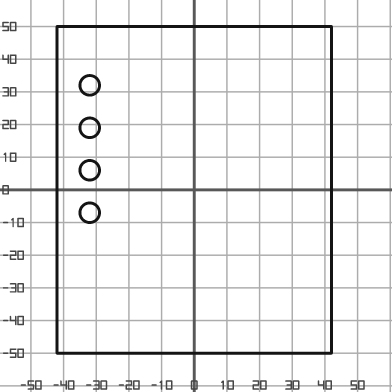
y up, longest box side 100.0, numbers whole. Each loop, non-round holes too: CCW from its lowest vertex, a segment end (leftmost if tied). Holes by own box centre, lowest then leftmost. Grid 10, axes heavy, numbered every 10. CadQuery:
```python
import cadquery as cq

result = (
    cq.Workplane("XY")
    .moveTo(-42.0, -50.0)
    .lineTo(42.0, -50.0)
    .lineTo(42.0, 50.0)
    .lineTo(-42.0, 50.0)
    .close()
    .moveTo(-32.0, -7.0)
    .circle(3.0)
    .moveTo(-32.0, 6.0)
    .circle(3.0)
    .moveTo(-32.0, 19.0)
    .circle(3.0)
    .moveTo(-32.0, 32.0)
    .circle(3.0)
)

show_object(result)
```